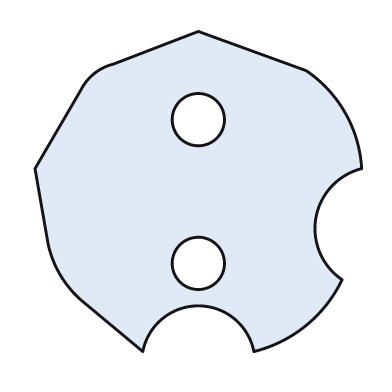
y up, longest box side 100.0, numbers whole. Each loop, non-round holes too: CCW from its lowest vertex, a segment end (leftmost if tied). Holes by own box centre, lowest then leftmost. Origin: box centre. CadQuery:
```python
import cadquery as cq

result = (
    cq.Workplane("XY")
    .moveTo(-17.0, -49.0)
    .threePointArc((0.0, -35.0), (17.0, -49.0))
    .threePointArc((33.0, -41.0), (44.0, -27.0))
    .threePointArc((36.0, -8.0), (50.0, 7.0))
    .threePointArc((45.0, 24.0), (33.0, 37.0))
    .lineTo(0.0, 49.0)
    .lineTo(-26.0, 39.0)
    .threePointArc((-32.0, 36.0), (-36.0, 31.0))
    .lineTo(-50.0, 7.0)
    .lineTo(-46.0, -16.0)
    .threePointArc((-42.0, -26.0), (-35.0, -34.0))
    .close()
    .moveTo(0.0, -22.0)
    .circle(8.0)
    .moveTo(0.0, 22.0)
    .circle(8.0)
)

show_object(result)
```